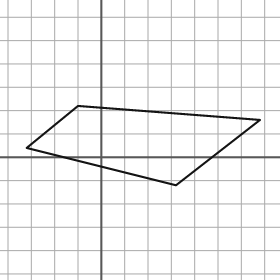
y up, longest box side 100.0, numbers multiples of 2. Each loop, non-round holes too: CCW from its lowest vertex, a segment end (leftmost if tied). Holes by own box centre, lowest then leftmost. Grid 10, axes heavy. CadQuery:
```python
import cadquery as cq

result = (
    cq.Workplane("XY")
    .moveTo(32.0, -12.0)
    .lineTo(68.0, 16.0)
    .lineTo(-10.0, 22.0)
    .lineTo(-32.0, 4.0)
    .close()
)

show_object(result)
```